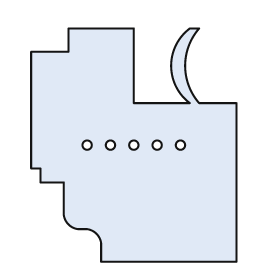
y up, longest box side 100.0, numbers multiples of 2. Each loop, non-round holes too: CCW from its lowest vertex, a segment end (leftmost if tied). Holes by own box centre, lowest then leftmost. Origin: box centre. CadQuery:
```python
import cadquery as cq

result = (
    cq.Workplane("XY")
    .moveTo(-14.0, -50.0)
    .lineTo(44.0, -50.0)
    .lineTo(44.0, 18.0)
    .lineTo(28.0, 18.0)
    .threePointArc((22.0, 34.0), (28.0, 50.0))
    .lineTo(24.0, 50.0)
    .threePointArc((16.0, 34.0), (24.0, 18.0))
    .lineTo(0.0, 18.0)
    .lineTo(0.0, 50.0)
    .lineTo(-28.0, 50.0)
    .lineTo(-28.0, 40.0)
    .lineTo(-44.0, 40.0)
    .lineTo(-44.0, -10.0)
    .lineTo(-40.0, -10.0)
    .lineTo(-40.0, -16.0)
    .lineTo(-30.0, -16.0)
    .lineTo(-30.0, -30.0)
    .threePointArc((-28.0, -34.0), (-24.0, -36.0))
    .lineTo(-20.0, -36.0)
    .threePointArc((-16.0, -38.0), (-14.0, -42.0))
    .close()
    .moveTo(-20.0, 0.0)
    .circle(2.0)
    .moveTo(-10.0, 0.0)
    .circle(2.0)
    .moveTo(0.0, 0.0)
    .circle(2.0)
    .moveTo(10.0, 0.0)
    .circle(2.0)
    .moveTo(20.0, 0.0)
    .circle(2.0)
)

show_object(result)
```